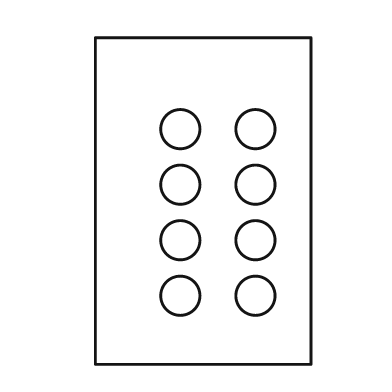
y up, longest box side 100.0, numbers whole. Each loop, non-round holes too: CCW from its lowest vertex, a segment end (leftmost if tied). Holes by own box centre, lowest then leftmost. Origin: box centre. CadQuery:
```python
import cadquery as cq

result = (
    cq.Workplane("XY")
    .moveTo(-33.0, -50.0)
    .lineTo(33.0, -50.0)
    .lineTo(33.0, 50.0)
    .lineTo(-33.0, 50.0)
    .close()
    .moveTo(-7.0, -29.0)
    .circle(6.0)
    .moveTo(16.0, -29.0)
    .circle(6.0)
    .moveTo(-7.0, -12.0)
    .circle(6.0)
    .moveTo(16.0, -12.0)
    .circle(6.0)
    .moveTo(-7.0, 5.0)
    .circle(6.0)
    .moveTo(16.0, 5.0)
    .circle(6.0)
    .moveTo(-7.0, 22.0)
    .circle(6.0)
    .moveTo(16.0, 22.0)
    .circle(6.0)
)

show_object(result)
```